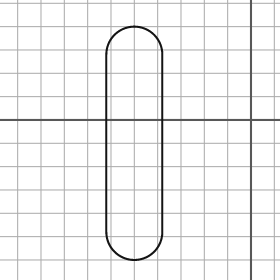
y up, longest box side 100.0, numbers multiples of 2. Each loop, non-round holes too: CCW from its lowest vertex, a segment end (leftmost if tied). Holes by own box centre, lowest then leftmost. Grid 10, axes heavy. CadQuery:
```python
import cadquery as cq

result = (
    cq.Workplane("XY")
    .moveTo(-62.0, -48.0)
    .threePointArc((-50.0, -60.0), (-38.0, -48.0))
    .lineTo(-38.0, 28.0)
    .threePointArc((-50.0, 40.0), (-62.0, 28.0))
    .close()
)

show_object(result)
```